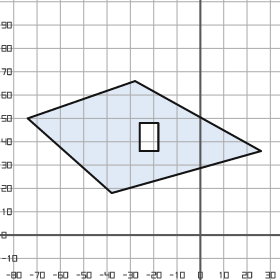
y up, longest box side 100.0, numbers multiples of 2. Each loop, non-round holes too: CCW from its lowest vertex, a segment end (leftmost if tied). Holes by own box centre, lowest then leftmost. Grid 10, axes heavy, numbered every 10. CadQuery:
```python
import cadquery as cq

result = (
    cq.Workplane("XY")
    .moveTo(-38.0, 18.0)
    .lineTo(26.0, 36.0)
    .lineTo(-28.0, 66.0)
    .lineTo(-74.0, 50.0)
    .close()
    .moveTo(-26.0, 36.0)
    .lineTo(-18.0, 36.0)
    .lineTo(-18.0, 48.0)
    .lineTo(-26.0, 48.0)
    .close()
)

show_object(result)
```